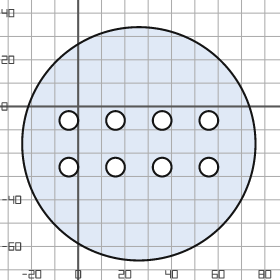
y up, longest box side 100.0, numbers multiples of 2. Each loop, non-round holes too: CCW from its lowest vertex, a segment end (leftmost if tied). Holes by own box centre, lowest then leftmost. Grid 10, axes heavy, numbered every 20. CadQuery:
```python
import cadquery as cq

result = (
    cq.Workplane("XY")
    .moveTo(26.0, -16.0)
    .circle(50.0)
    .moveTo(-4.0, -26.0)
    .circle(4.0)
    .moveTo(16.0, -26.0)
    .circle(4.0)
    .moveTo(36.0, -26.0)
    .circle(4.0)
    .moveTo(56.0, -26.0)
    .circle(4.0)
    .moveTo(-4.0, -6.0)
    .circle(4.0)
    .moveTo(16.0, -6.0)
    .circle(4.0)
    .moveTo(36.0, -6.0)
    .circle(4.0)
    .moveTo(56.0, -6.0)
    .circle(4.0)
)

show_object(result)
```